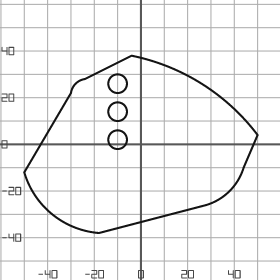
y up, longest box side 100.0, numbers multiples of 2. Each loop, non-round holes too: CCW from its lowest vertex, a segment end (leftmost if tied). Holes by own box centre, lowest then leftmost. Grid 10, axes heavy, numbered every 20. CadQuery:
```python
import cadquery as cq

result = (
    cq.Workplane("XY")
    .moveTo(-18.0, -38.0)
    .lineTo(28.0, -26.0)
    .threePointArc((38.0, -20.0), (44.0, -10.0))
    .lineTo(50.0, 4.0)
    .threePointArc((26.0, 26.0), (-4.0, 38.0))
    .lineTo(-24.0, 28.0)
    .threePointArc((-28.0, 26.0), (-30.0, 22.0))
    .lineTo(-50.0, -12.0)
    .threePointArc((-38.0, -30.0), (-18.0, -38.0))
    .close()
    .moveTo(-10.0, 2.0)
    .circle(4.0)
    .moveTo(-10.0, 14.0)
    .circle(4.0)
    .moveTo(-10.0, 26.0)
    .circle(4.0)
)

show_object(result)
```